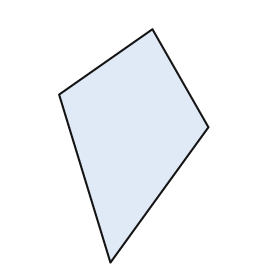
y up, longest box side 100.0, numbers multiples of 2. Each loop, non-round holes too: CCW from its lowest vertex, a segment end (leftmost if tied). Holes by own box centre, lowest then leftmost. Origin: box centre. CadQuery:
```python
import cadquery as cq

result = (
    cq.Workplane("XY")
    .moveTo(-10.0, -50.0)
    .lineTo(32.0, 8.0)
    .lineTo(8.0, 50.0)
    .lineTo(-32.0, 22.0)
    .close()
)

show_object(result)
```